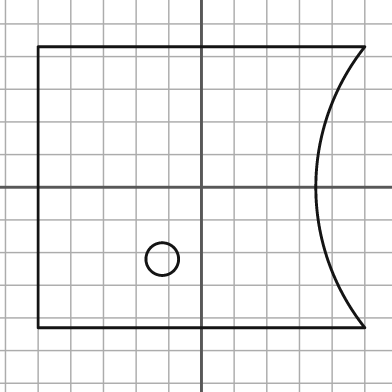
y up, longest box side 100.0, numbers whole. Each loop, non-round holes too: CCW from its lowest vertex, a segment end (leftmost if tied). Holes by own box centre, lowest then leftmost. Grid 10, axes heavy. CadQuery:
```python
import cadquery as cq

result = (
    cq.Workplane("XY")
    .moveTo(-50.0, -43.0)
    .lineTo(50.0, -43.0)
    .threePointArc((35.0, 0.0), (50.0, 43.0))
    .lineTo(-50.0, 43.0)
    .close()
    .moveTo(-12.0, -22.0)
    .circle(5.0)
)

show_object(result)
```